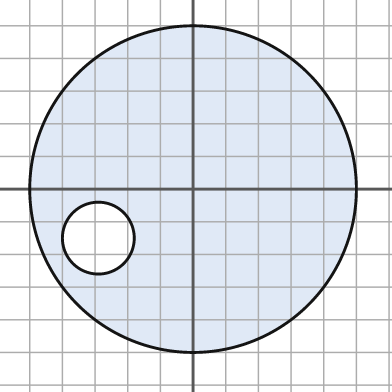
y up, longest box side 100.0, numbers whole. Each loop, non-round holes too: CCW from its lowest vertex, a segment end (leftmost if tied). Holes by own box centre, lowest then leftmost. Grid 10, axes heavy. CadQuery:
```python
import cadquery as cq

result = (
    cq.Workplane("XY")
    .moveTo(0.0, 0.0)
    .circle(50.0)
    .moveTo(-29.0, -15.0)
    .circle(11.0)
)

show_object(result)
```